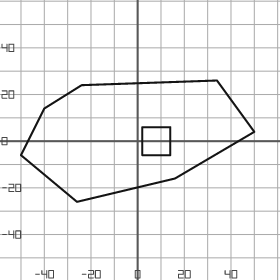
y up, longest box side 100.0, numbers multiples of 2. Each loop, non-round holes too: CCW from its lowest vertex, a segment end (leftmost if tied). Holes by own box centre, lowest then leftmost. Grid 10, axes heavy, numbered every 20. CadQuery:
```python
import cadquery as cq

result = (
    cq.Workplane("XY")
    .moveTo(-26.0, -26.0)
    .lineTo(16.0, -16.0)
    .lineTo(50.0, 4.0)
    .lineTo(34.0, 26.0)
    .lineTo(-24.0, 24.0)
    .lineTo(-40.0, 14.0)
    .lineTo(-50.0, -6.0)
    .close()
    .moveTo(2.0, -6.0)
    .lineTo(14.0, -6.0)
    .lineTo(14.0, 6.0)
    .lineTo(2.0, 6.0)
    .close()
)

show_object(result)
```